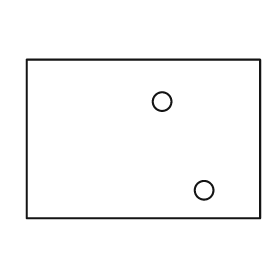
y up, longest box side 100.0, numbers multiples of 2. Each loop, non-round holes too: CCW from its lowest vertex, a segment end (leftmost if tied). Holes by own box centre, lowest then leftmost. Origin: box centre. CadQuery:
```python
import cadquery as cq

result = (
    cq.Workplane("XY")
    .moveTo(-50.0, -34.0)
    .lineTo(50.0, -34.0)
    .lineTo(50.0, 34.0)
    .lineTo(-50.0, 34.0)
    .close()
    .moveTo(26.0, -22.0)
    .circle(4.0)
    .moveTo(8.0, 16.0)
    .circle(4.0)
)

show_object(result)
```